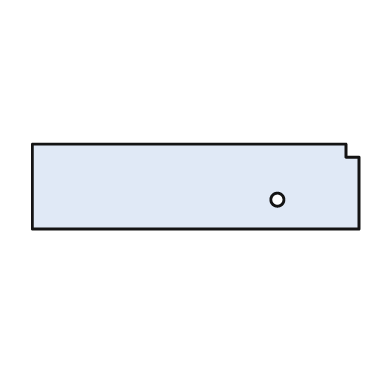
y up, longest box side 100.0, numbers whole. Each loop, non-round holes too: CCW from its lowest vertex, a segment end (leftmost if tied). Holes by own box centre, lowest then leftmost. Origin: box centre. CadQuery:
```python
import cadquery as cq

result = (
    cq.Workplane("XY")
    .moveTo(-50.0, -13.0)
    .lineTo(50.0, -13.0)
    .lineTo(50.0, 9.0)
    .lineTo(46.0, 9.0)
    .lineTo(46.0, 13.0)
    .lineTo(-50.0, 13.0)
    .close()
    .moveTo(25.0, -4.0)
    .circle(2.0)
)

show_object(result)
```